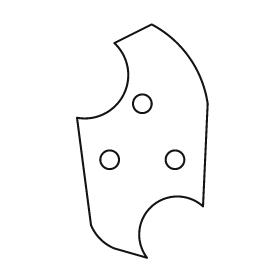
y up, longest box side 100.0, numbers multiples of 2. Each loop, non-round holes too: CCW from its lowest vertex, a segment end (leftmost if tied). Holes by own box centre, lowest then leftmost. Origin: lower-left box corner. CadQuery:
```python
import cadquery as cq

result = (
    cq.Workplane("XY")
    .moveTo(30.0, 0.0)
    .threePointArc((32.0, 22.0), (54.0, 22.0))
    .lineTo(56.0, 66.0)
    .threePointArc((48.0, 86.0), (32.0, 100.0))
    .lineTo(16.0, 92.0)
    .threePointArc((20.0, 70.0), (0.0, 60.0))
    .lineTo(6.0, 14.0)
    .threePointArc((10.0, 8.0), (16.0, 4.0))
    .close()
    .moveTo(14.0, 42.0)
    .circle(4.0)
    .moveTo(42.0, 42.0)
    .circle(4.0)
    .moveTo(28.0, 66.0)
    .circle(4.0)
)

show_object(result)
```